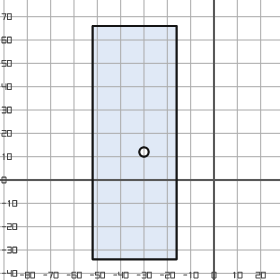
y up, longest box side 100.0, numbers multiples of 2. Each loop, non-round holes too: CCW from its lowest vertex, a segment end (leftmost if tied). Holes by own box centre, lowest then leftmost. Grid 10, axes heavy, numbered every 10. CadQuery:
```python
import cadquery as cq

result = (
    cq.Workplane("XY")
    .moveTo(-52.0, -34.0)
    .lineTo(-16.0, -34.0)
    .lineTo(-16.0, 66.0)
    .lineTo(-52.0, 66.0)
    .close()
    .moveTo(-30.0, 12.0)
    .circle(2.0)
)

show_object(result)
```